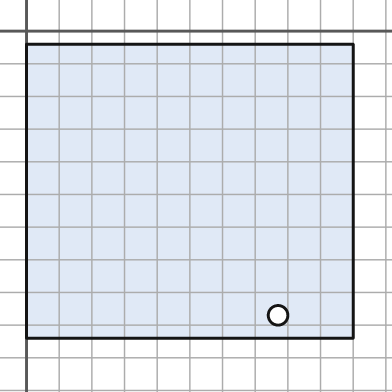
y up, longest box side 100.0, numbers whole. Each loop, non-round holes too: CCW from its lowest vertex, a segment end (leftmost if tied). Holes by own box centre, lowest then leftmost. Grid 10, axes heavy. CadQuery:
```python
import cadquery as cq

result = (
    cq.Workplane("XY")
    .moveTo(0.0, -94.0)
    .lineTo(100.0, -94.0)
    .lineTo(100.0, -4.0)
    .lineTo(0.0, -4.0)
    .close()
    .moveTo(77.0, -87.0)
    .circle(3.0)
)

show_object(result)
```